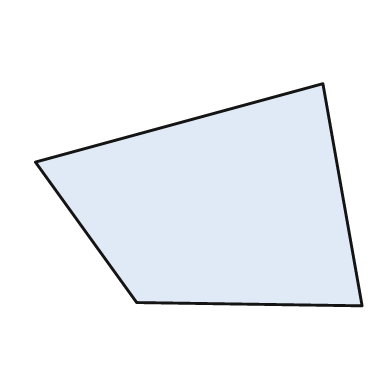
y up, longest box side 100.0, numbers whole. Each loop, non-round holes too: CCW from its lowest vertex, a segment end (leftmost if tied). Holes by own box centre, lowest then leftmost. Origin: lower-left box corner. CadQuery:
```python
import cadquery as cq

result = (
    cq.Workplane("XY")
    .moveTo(100.0, 0.0)
    .lineTo(88.0, 68.0)
    .lineTo(0.0, 44.0)
    .lineTo(31.0, 1.0)
    .close()
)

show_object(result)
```